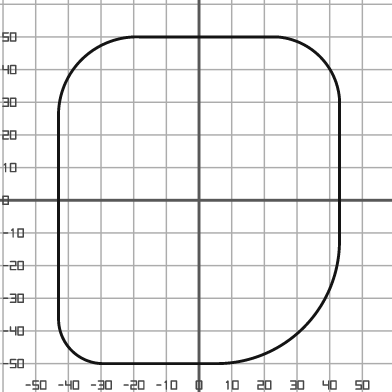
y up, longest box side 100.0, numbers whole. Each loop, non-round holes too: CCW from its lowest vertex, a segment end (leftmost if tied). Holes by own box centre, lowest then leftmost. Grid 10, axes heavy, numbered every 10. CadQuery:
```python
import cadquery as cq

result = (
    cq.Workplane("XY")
    .moveTo(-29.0, -50.0)
    .lineTo(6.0, -50.0)
    .threePointArc((32.0, -39.0), (43.0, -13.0))
    .lineTo(43.0, 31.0)
    .threePointArc((37.0, 44.0), (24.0, 50.0))
    .lineTo(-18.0, 50.0)
    .threePointArc((-36.0, 43.0), (-43.0, 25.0))
    .lineTo(-43.0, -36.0)
    .threePointArc((-39.0, -46.0), (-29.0, -50.0))
    .close()
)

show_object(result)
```